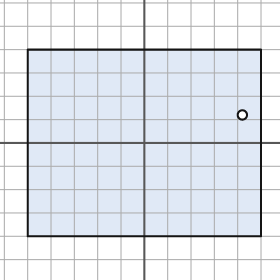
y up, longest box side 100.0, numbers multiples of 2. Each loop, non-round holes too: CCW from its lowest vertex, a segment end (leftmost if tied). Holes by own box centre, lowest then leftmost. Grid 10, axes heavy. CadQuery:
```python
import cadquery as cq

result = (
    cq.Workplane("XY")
    .moveTo(-50.0, -40.0)
    .lineTo(50.0, -40.0)
    .lineTo(50.0, 40.0)
    .lineTo(-50.0, 40.0)
    .close()
    .moveTo(42.0, 12.0)
    .circle(2.0)
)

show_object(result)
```